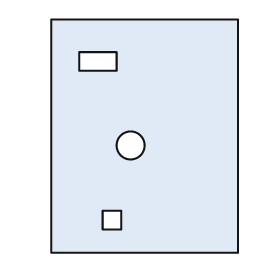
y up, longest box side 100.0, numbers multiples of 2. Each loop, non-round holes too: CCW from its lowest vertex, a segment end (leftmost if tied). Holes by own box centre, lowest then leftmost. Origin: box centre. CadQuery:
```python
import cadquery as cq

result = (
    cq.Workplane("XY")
    .moveTo(-40.0, -50.0)
    .lineTo(40.0, -50.0)
    .lineTo(40.0, 50.0)
    .lineTo(-40.0, 50.0)
    .close()
    .moveTo(-18.0, -40.0)
    .lineTo(-10.0, -40.0)
    .lineTo(-10.0, -32.0)
    .lineTo(-18.0, -32.0)
    .close()
    .moveTo(-6.0, -4.0)
    .circle(6.0)
    .moveTo(-28.0, 28.0)
    .lineTo(-12.0, 28.0)
    .lineTo(-12.0, 36.0)
    .lineTo(-28.0, 36.0)
    .close()
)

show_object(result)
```